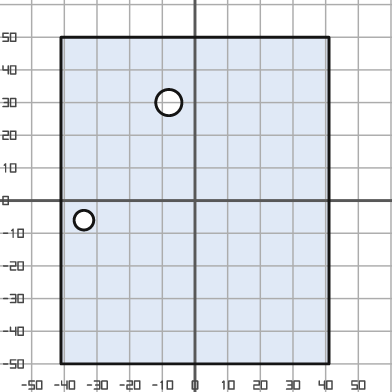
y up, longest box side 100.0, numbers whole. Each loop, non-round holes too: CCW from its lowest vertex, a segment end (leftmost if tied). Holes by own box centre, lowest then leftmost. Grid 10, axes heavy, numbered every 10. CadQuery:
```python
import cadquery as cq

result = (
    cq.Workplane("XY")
    .moveTo(-41.0, -50.0)
    .lineTo(41.0, -50.0)
    .lineTo(41.0, 50.0)
    .lineTo(-41.0, 50.0)
    .close()
    .moveTo(-34.0, -6.0)
    .circle(3.0)
    .moveTo(-8.0, 30.0)
    .circle(4.0)
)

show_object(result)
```